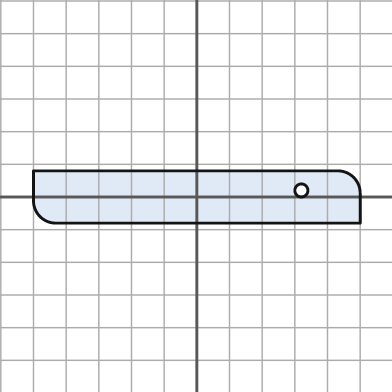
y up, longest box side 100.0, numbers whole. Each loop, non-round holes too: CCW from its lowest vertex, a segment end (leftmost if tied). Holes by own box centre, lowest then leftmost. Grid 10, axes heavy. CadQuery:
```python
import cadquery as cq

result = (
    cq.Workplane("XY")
    .moveTo(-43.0, -8.0)
    .lineTo(50.0, -8.0)
    .lineTo(50.0, 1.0)
    .threePointArc((48.0, 6.0), (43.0, 8.0))
    .lineTo(-50.0, 8.0)
    .lineTo(-50.0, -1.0)
    .threePointArc((-48.0, -6.0), (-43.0, -8.0))
    .close()
    .moveTo(32.0, 2.0)
    .circle(2.0)
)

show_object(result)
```